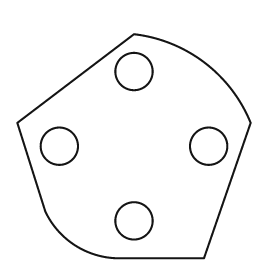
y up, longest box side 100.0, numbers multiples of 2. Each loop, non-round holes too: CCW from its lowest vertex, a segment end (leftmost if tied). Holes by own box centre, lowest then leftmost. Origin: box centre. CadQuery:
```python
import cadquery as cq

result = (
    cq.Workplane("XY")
    .moveTo(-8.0, -48.0)
    .lineTo(30.0, -48.0)
    .lineTo(50.0, 10.0)
    .threePointArc((30.0, 36.0), (0.0, 48.0))
    .lineTo(-50.0, 10.0)
    .lineTo(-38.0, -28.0)
    .threePointArc((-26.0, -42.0), (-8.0, -48.0))
    .close()
    .moveTo(0.0, -32.0)
    .circle(8.0)
    .moveTo(-32.0, 0.0)
    .circle(8.0)
    .moveTo(32.0, 0.0)
    .circle(8.0)
    .moveTo(0.0, 32.0)
    .circle(8.0)
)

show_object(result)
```